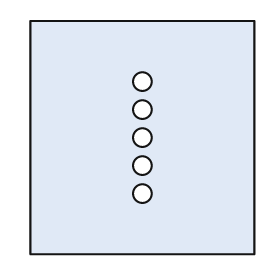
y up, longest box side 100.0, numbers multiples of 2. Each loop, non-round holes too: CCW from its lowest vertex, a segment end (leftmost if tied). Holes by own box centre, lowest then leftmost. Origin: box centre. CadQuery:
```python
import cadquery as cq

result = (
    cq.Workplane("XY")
    .moveTo(-48.0, -50.0)
    .lineTo(48.0, -50.0)
    .lineTo(48.0, 50.0)
    .lineTo(-48.0, 50.0)
    .close()
    .moveTo(0.0, -24.0)
    .circle(4.0)
    .moveTo(0.0, -12.0)
    .circle(4.0)
    .moveTo(0.0, 0.0)
    .circle(4.0)
    .moveTo(0.0, 12.0)
    .circle(4.0)
    .moveTo(0.0, 24.0)
    .circle(4.0)
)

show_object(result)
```